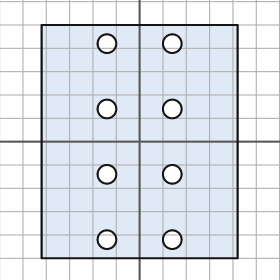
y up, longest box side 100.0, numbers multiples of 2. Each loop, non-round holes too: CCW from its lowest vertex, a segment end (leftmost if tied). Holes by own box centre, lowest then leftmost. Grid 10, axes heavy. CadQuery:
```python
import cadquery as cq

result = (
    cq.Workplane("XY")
    .moveTo(-42.0, -50.0)
    .lineTo(42.0, -50.0)
    .lineTo(42.0, 50.0)
    .lineTo(-42.0, 50.0)
    .close()
    .moveTo(-14.0, -42.0)
    .circle(4.0)
    .moveTo(14.0, -42.0)
    .circle(4.0)
    .moveTo(-14.0, -14.0)
    .circle(4.0)
    .moveTo(14.0, -14.0)
    .circle(4.0)
    .moveTo(-14.0, 14.0)
    .circle(4.0)
    .moveTo(14.0, 14.0)
    .circle(4.0)
    .moveTo(-14.0, 42.0)
    .circle(4.0)
    .moveTo(14.0, 42.0)
    .circle(4.0)
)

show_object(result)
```